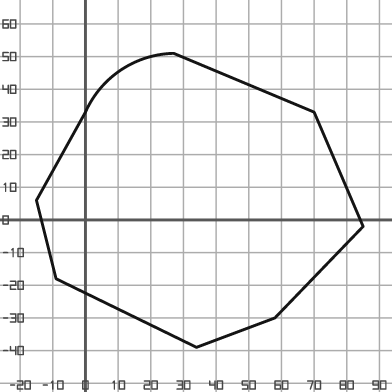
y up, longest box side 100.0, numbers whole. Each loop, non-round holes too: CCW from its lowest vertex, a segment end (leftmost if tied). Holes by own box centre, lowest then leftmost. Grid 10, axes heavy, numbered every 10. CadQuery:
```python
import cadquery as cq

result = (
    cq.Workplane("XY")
    .moveTo(34.0, -39.0)
    .lineTo(58.0, -30.0)
    .lineTo(85.0, -2.0)
    .lineTo(70.0, 33.0)
    .lineTo(27.0, 51.0)
    .threePointArc((11.0, 46.0), (0.0, 33.0))
    .lineTo(-15.0, 6.0)
    .lineTo(-9.0, -18.0)
    .close()
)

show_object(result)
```